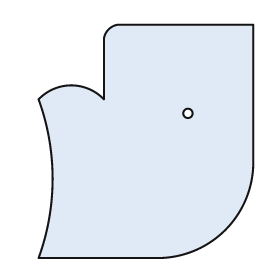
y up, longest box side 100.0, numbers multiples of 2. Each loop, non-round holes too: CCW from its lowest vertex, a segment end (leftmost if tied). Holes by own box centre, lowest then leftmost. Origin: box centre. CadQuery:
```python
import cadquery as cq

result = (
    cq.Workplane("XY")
    .moveTo(-46.0, -50.0)
    .lineTo(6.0, -50.0)
    .threePointArc((34.0, -38.0), (46.0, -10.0))
    .lineTo(46.0, 50.0)
    .lineTo(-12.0, 50.0)
    .threePointArc((-16.0, 48.0), (-18.0, 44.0))
    .lineTo(-18.0, 18.0)
    .threePointArc((-32.0, 24.0), (-46.0, 18.0))
    .threePointArc((-40.0, -16.0), (-46.0, -50.0))
    .close()
    .moveTo(18.0, 12.0)
    .circle(2.0)
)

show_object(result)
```